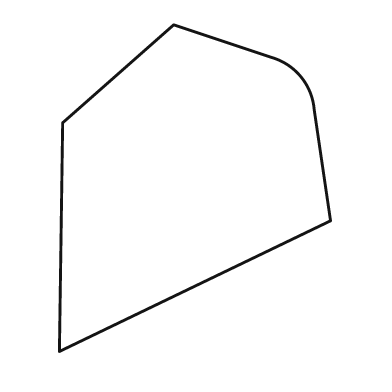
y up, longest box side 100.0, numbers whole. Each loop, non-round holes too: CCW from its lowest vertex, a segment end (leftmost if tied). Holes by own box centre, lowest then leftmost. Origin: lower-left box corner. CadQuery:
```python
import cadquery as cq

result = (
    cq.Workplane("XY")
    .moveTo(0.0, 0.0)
    .lineTo(83.0, 40.0)
    .lineTo(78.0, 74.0)
    .threePointArc((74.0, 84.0), (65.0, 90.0))
    .lineTo(35.0, 100.0)
    .lineTo(1.0, 70.0)
    .close()
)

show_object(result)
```